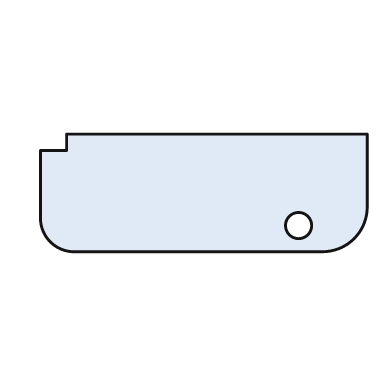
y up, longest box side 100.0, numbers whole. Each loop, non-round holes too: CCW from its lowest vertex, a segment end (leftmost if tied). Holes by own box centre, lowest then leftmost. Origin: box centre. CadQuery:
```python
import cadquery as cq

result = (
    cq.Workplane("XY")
    .moveTo(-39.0, -18.0)
    .lineTo(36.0, -18.0)
    .threePointArc((46.0, -14.0), (50.0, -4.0))
    .lineTo(50.0, 18.0)
    .lineTo(-42.0, 18.0)
    .lineTo(-42.0, 13.0)
    .lineTo(-50.0, 13.0)
    .lineTo(-50.0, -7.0)
    .threePointArc((-47.0, -15.0), (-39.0, -18.0))
    .close()
    .moveTo(29.0, -10.0)
    .circle(4.0)
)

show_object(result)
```